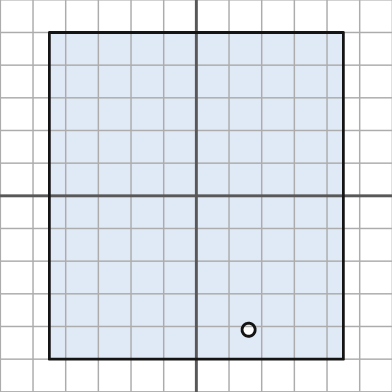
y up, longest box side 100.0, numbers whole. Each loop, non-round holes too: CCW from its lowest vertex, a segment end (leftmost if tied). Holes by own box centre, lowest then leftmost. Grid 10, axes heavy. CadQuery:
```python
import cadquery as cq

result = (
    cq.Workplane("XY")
    .moveTo(-45.0, -50.0)
    .lineTo(45.0, -50.0)
    .lineTo(45.0, 50.0)
    .lineTo(-45.0, 50.0)
    .close()
    .moveTo(16.0, -41.0)
    .circle(2.0)
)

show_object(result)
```